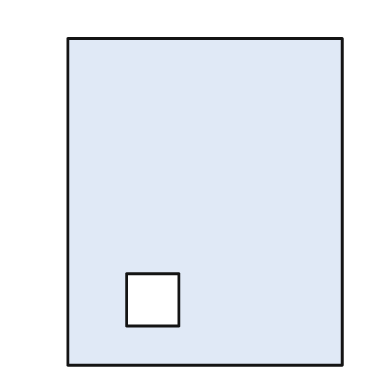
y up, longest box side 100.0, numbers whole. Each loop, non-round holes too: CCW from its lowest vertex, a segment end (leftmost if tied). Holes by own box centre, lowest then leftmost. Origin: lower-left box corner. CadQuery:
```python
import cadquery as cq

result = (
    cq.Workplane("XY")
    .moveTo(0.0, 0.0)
    .lineTo(84.0, 0.0)
    .lineTo(84.0, 100.0)
    .lineTo(0.0, 100.0)
    .close()
    .moveTo(18.0, 12.0)
    .lineTo(34.0, 12.0)
    .lineTo(34.0, 28.0)
    .lineTo(18.0, 28.0)
    .close()
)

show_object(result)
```